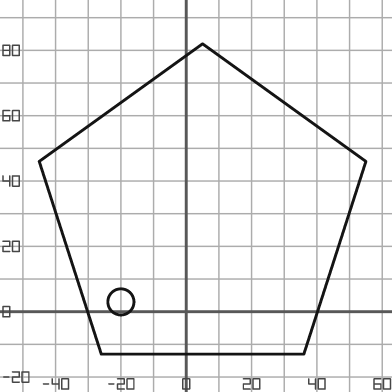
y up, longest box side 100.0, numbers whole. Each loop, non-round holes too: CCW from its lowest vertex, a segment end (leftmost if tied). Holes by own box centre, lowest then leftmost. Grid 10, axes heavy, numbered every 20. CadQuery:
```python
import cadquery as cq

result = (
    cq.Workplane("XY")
    .moveTo(-26.0, -13.0)
    .lineTo(36.0, -13.0)
    .lineTo(55.0, 46.0)
    .lineTo(5.0, 82.0)
    .lineTo(-45.0, 46.0)
    .close()
    .moveTo(-20.0, 3.0)
    .circle(4.0)
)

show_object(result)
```